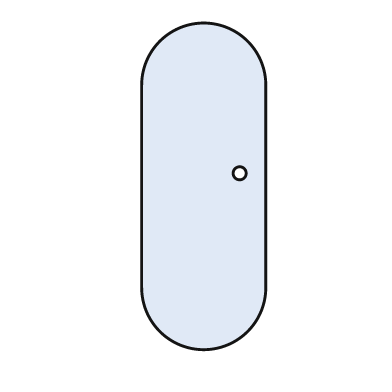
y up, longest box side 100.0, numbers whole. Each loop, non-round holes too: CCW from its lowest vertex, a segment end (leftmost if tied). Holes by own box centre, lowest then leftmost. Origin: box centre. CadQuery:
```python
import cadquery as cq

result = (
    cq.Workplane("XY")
    .moveTo(-19.0, -31.0)
    .threePointArc((0.0, -50.0), (19.0, -31.0))
    .lineTo(19.0, 31.0)
    .threePointArc((0.0, 50.0), (-19.0, 31.0))
    .close()
    .moveTo(11.0, 4.0)
    .circle(2.0)
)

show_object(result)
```